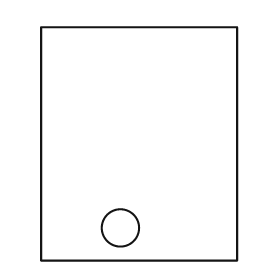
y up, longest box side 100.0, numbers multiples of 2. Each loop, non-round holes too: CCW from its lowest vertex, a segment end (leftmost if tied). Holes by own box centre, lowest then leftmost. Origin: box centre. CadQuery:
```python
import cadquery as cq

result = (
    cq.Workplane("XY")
    .moveTo(-42.0, -50.0)
    .lineTo(42.0, -50.0)
    .lineTo(42.0, 50.0)
    .lineTo(-42.0, 50.0)
    .close()
    .moveTo(-8.0, -36.0)
    .circle(8.0)
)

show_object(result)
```